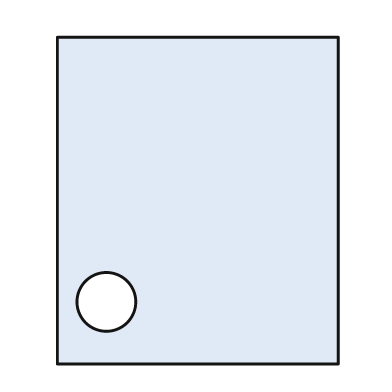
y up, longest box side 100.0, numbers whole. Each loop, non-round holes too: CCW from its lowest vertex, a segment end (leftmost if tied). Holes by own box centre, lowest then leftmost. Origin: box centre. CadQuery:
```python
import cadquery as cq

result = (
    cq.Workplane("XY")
    .moveTo(-43.0, -50.0)
    .lineTo(43.0, -50.0)
    .lineTo(43.0, 50.0)
    .lineTo(-43.0, 50.0)
    .close()
    .moveTo(-28.0, -31.0)
    .circle(9.0)
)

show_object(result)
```